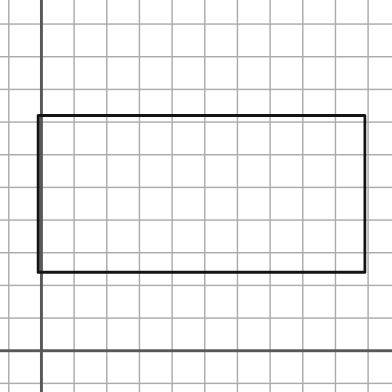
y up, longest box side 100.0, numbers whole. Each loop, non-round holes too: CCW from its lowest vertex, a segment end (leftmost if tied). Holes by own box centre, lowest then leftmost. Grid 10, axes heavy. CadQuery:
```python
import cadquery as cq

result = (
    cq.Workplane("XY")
    .moveTo(-1.0, 24.0)
    .lineTo(99.0, 24.0)
    .lineTo(99.0, 72.0)
    .lineTo(-1.0, 72.0)
    .close()
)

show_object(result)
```